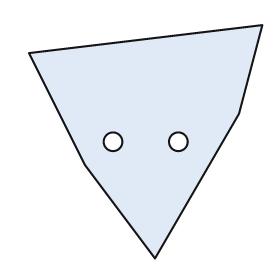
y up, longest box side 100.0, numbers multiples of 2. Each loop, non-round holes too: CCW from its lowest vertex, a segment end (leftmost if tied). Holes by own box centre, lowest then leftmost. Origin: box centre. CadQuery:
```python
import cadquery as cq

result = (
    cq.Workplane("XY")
    .moveTo(4.0, -50.0)
    .lineTo(40.0, 12.0)
    .lineTo(50.0, 50.0)
    .lineTo(-50.0, 38.0)
    .lineTo(-26.0, -10.0)
    .close()
    .moveTo(-14.0, 0.0)
    .circle(4.0)
    .moveTo(14.0, 0.0)
    .circle(4.0)
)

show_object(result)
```